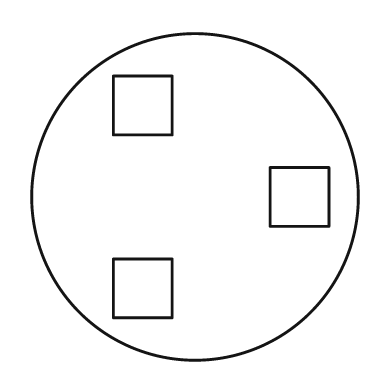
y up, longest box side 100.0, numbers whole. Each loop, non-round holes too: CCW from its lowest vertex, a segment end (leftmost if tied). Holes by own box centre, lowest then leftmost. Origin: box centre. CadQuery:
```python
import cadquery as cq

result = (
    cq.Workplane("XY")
    .moveTo(0.0, 0.0)
    .circle(50.0)
    .moveTo(-25.0, -37.0)
    .lineTo(-7.0, -37.0)
    .lineTo(-7.0, -19.0)
    .lineTo(-25.0, -19.0)
    .close()
    .moveTo(23.0, -9.0)
    .lineTo(41.0, -9.0)
    .lineTo(41.0, 9.0)
    .lineTo(23.0, 9.0)
    .close()
    .moveTo(-25.0, 19.0)
    .lineTo(-7.0, 19.0)
    .lineTo(-7.0, 37.0)
    .lineTo(-25.0, 37.0)
    .close()
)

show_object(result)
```